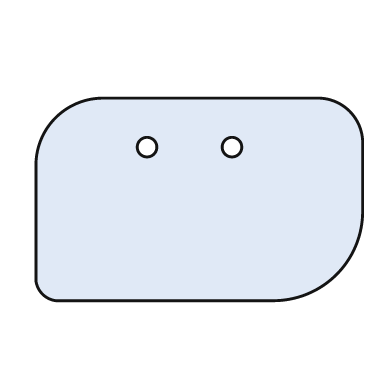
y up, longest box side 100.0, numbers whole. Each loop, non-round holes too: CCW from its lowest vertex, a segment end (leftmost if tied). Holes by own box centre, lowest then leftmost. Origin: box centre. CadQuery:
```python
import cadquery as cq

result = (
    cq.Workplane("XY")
    .moveTo(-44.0, -31.0)
    .lineTo(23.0, -31.0)
    .threePointArc((42.0, -23.0), (50.0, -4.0))
    .lineTo(50.0, 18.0)
    .threePointArc((46.0, 27.0), (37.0, 31.0))
    .lineTo(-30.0, 31.0)
    .threePointArc((-44.0, 25.0), (-50.0, 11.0))
    .lineTo(-50.0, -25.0)
    .threePointArc((-48.0, -29.0), (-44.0, -31.0))
    .close()
    .moveTo(-16.0, 16.0)
    .circle(3.0)
    .moveTo(10.0, 16.0)
    .circle(3.0)
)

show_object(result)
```